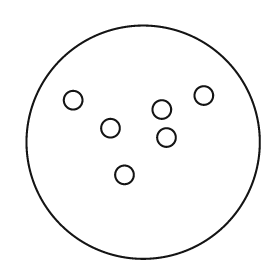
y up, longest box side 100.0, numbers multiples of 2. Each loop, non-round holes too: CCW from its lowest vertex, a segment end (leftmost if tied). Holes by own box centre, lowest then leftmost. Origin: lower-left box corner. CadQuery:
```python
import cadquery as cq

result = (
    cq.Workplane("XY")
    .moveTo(50.0, 50.0)
    .circle(50.0)
    .moveTo(42.0, 36.0)
    .circle(4.0)
    .moveTo(60.0, 52.0)
    .circle(4.0)
    .moveTo(36.0, 56.0)
    .circle(4.0)
    .moveTo(58.0, 64.0)
    .circle(4.0)
    .moveTo(20.0, 68.0)
    .circle(4.0)
    .moveTo(76.0, 70.0)
    .circle(4.0)
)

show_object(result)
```